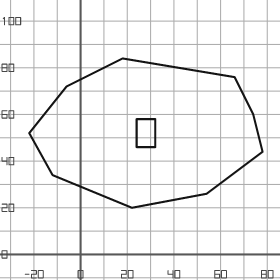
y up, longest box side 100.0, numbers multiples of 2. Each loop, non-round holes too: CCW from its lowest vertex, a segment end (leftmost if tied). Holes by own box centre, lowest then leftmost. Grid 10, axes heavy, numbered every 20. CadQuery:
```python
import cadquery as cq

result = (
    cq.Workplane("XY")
    .moveTo(22.0, 20.0)
    .lineTo(54.0, 26.0)
    .lineTo(78.0, 44.0)
    .lineTo(74.0, 60.0)
    .lineTo(66.0, 76.0)
    .lineTo(18.0, 84.0)
    .lineTo(-6.0, 72.0)
    .lineTo(-22.0, 52.0)
    .lineTo(-12.0, 34.0)
    .close()
    .moveTo(24.0, 46.0)
    .lineTo(32.0, 46.0)
    .lineTo(32.0, 58.0)
    .lineTo(24.0, 58.0)
    .close()
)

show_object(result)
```